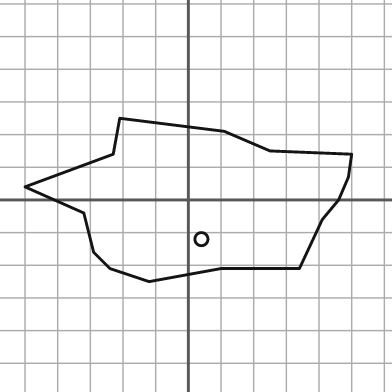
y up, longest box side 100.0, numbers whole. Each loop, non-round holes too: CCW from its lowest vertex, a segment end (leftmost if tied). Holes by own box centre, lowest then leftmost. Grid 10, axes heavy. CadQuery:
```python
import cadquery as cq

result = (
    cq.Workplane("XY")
    .moveTo(-12.0, -25.0)
    .lineTo(10.0, -21.0)
    .lineTo(34.0, -21.0)
    .lineTo(41.0, -6.0)
    .lineTo(46.0, 0.0)
    .lineTo(49.0, 7.0)
    .lineTo(50.0, 14.0)
    .lineTo(25.0, 15.0)
    .lineTo(11.0, 21.0)
    .lineTo(-21.0, 25.0)
    .lineTo(-23.0, 14.0)
    .lineTo(-50.0, 4.0)
    .lineTo(-32.0, -4.0)
    .lineTo(-29.0, -16.0)
    .lineTo(-24.0, -21.0)
    .close()
    .moveTo(4.0, -12.0)
    .circle(2.0)
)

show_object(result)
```